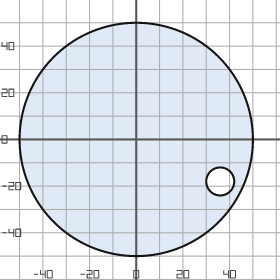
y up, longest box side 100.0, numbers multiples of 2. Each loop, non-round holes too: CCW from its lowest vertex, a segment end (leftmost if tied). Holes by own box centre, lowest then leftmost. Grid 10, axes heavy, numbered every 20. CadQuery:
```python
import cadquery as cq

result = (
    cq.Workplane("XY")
    .moveTo(0.0, 0.0)
    .circle(50.0)
    .moveTo(36.0, -18.0)
    .circle(6.0)
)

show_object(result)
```